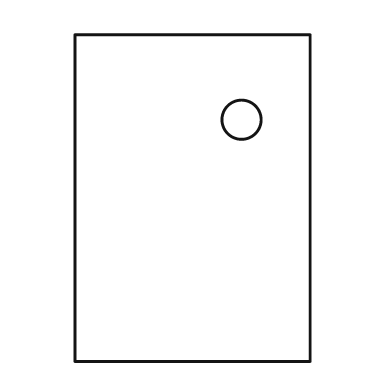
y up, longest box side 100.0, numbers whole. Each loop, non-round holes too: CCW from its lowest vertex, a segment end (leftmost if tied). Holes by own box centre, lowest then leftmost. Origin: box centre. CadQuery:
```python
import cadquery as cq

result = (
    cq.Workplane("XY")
    .moveTo(-36.0, -50.0)
    .lineTo(36.0, -50.0)
    .lineTo(36.0, 50.0)
    .lineTo(-36.0, 50.0)
    .close()
    .moveTo(15.0, 24.0)
    .circle(6.0)
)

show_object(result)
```